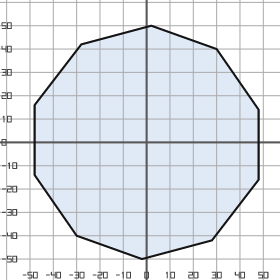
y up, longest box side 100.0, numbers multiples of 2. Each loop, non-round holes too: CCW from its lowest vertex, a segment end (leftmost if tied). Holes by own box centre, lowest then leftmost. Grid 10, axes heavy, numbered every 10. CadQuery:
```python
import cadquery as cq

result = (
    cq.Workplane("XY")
    .moveTo(-2.0, -50.0)
    .lineTo(28.0, -42.0)
    .lineTo(48.0, -16.0)
    .lineTo(48.0, 14.0)
    .lineTo(30.0, 40.0)
    .lineTo(2.0, 50.0)
    .lineTo(-28.0, 42.0)
    .lineTo(-48.0, 16.0)
    .lineTo(-48.0, -14.0)
    .lineTo(-30.0, -40.0)
    .close()
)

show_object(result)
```